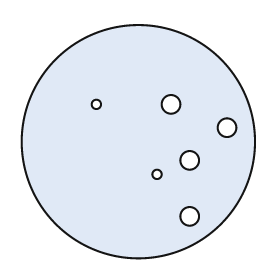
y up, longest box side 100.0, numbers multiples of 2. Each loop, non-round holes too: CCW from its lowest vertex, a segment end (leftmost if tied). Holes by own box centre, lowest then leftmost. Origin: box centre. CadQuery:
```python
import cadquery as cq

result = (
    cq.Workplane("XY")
    .moveTo(0.0, 0.0)
    .circle(50.0)
    .moveTo(22.0, -32.0)
    .circle(4.0)
    .moveTo(8.0, -14.0)
    .circle(2.0)
    .moveTo(22.0, -8.0)
    .circle(4.0)
    .moveTo(38.0, 6.0)
    .circle(4.0)
    .moveTo(-18.0, 16.0)
    .circle(2.0)
    .moveTo(14.0, 16.0)
    .circle(4.0)
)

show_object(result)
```